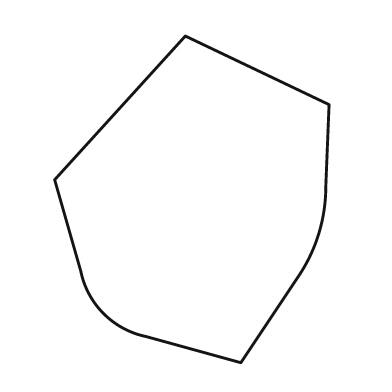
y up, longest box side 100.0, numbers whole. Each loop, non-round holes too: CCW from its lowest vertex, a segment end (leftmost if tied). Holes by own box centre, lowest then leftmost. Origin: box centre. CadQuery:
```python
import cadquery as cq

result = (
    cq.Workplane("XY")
    .moveTo(15.0, -50.0)
    .lineTo(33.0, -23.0)
    .threePointArc((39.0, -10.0), (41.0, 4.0))
    .lineTo(42.0, 29.0)
    .lineTo(-2.0, 50.0)
    .lineTo(-42.0, 6.0)
    .lineTo(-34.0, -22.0)
    .threePointArc((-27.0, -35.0), (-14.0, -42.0))
    .close()
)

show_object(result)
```